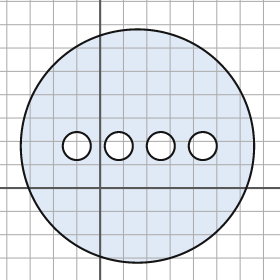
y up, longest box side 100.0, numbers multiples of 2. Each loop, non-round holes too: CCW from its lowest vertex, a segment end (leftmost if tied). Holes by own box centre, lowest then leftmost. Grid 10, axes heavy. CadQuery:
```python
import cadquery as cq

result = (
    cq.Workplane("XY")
    .moveTo(16.0, 18.0)
    .circle(50.0)
    .moveTo(-10.0, 18.0)
    .circle(6.0)
    .moveTo(8.0, 18.0)
    .circle(6.0)
    .moveTo(26.0, 18.0)
    .circle(6.0)
    .moveTo(44.0, 18.0)
    .circle(6.0)
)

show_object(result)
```